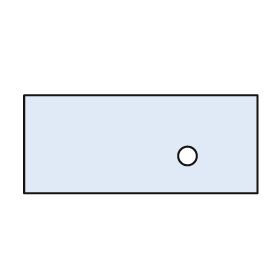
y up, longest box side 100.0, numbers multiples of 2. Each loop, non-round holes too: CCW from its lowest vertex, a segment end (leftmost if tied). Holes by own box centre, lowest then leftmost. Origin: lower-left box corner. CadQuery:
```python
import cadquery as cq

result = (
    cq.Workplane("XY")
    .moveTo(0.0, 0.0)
    .lineTo(100.0, 0.0)
    .lineTo(100.0, 42.0)
    .lineTo(0.0, 42.0)
    .close()
    .moveTo(70.0, 16.0)
    .circle(4.0)
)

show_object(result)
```